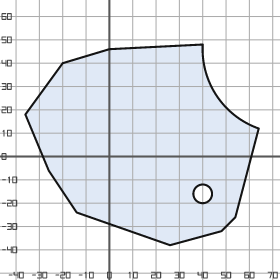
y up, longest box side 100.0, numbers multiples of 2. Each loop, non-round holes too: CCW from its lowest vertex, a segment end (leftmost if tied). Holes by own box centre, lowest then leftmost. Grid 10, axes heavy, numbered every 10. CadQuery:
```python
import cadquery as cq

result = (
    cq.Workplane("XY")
    .moveTo(26.0, -38.0)
    .lineTo(48.0, -32.0)
    .lineTo(54.0, -26.0)
    .lineTo(64.0, 12.0)
    .threePointArc((46.0, 26.0), (40.0, 48.0))
    .lineTo(0.0, 46.0)
    .lineTo(-20.0, 40.0)
    .lineTo(-36.0, 18.0)
    .lineTo(-26.0, -6.0)
    .lineTo(-14.0, -24.0)
    .close()
    .moveTo(40.0, -16.0)
    .circle(4.0)
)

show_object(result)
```